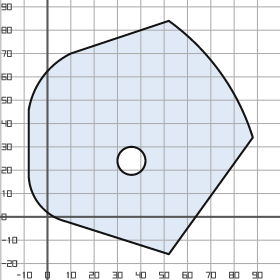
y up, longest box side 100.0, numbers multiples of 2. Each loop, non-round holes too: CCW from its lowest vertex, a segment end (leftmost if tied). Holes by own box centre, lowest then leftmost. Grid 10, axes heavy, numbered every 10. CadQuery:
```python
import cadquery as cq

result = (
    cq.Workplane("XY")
    .moveTo(52.0, -16.0)
    .lineTo(88.0, 34.0)
    .threePointArc((74.0, 62.0), (52.0, 84.0))
    .lineTo(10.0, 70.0)
    .threePointArc((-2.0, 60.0), (-8.0, 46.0))
    .lineTo(-8.0, 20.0)
    .threePointArc((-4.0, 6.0), (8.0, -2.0))
    .close()
    .moveTo(36.0, 24.0)
    .circle(6.0)
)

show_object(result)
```